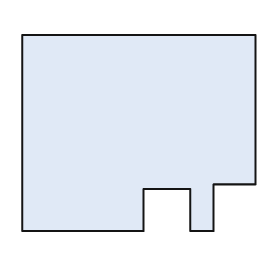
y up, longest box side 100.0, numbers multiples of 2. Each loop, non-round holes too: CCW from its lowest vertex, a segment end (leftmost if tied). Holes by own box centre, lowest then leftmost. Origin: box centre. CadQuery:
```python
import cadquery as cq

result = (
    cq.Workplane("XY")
    .moveTo(-50.0, -42.0)
    .lineTo(2.0, -42.0)
    .lineTo(2.0, -24.0)
    .lineTo(22.0, -24.0)
    .lineTo(22.0, -42.0)
    .lineTo(32.0, -42.0)
    .lineTo(32.0, -22.0)
    .lineTo(50.0, -22.0)
    .lineTo(50.0, 42.0)
    .lineTo(-50.0, 42.0)
    .close()
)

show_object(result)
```